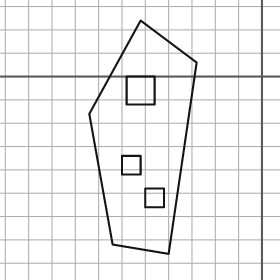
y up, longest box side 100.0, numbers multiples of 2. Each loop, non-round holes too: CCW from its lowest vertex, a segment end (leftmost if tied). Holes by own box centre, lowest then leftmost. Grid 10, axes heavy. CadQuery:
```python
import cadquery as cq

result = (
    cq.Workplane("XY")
    .moveTo(-40.0, -76.0)
    .lineTo(-28.0, 6.0)
    .lineTo(-52.0, 24.0)
    .lineTo(-74.0, -16.0)
    .lineTo(-64.0, -72.0)
    .close()
    .moveTo(-50.0, -56.0)
    .lineTo(-42.0, -56.0)
    .lineTo(-42.0, -48.0)
    .lineTo(-50.0, -48.0)
    .close()
    .moveTo(-60.0, -42.0)
    .lineTo(-52.0, -42.0)
    .lineTo(-52.0, -34.0)
    .lineTo(-60.0, -34.0)
    .close()
    .moveTo(-58.0, -12.0)
    .lineTo(-46.0, -12.0)
    .lineTo(-46.0, 0.0)
    .lineTo(-58.0, 0.0)
    .close()
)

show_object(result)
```